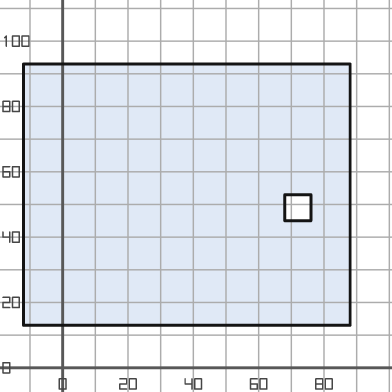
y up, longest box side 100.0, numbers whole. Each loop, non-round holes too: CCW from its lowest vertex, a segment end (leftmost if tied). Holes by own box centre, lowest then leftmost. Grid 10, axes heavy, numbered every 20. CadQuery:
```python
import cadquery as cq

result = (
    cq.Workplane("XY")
    .moveTo(-12.0, 13.0)
    .lineTo(88.0, 13.0)
    .lineTo(88.0, 93.0)
    .lineTo(-12.0, 93.0)
    .close()
    .moveTo(68.0, 45.0)
    .lineTo(76.0, 45.0)
    .lineTo(76.0, 53.0)
    .lineTo(68.0, 53.0)
    .close()
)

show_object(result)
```